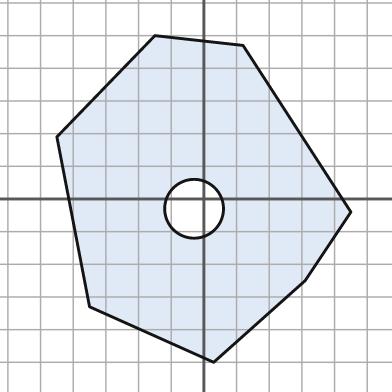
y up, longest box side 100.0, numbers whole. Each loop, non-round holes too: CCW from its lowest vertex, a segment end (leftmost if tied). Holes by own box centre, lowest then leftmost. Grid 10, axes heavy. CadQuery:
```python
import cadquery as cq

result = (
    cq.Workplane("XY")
    .moveTo(3.0, -50.0)
    .lineTo(31.0, -25.0)
    .lineTo(45.0, -4.0)
    .lineTo(12.0, 47.0)
    .lineTo(-15.0, 50.0)
    .lineTo(-45.0, 19.0)
    .lineTo(-35.0, -33.0)
    .close()
    .moveTo(-3.0, -3.0)
    .circle(9.0)
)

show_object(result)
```